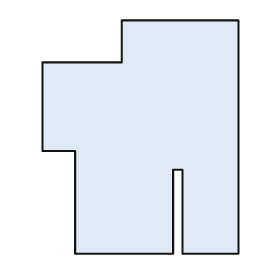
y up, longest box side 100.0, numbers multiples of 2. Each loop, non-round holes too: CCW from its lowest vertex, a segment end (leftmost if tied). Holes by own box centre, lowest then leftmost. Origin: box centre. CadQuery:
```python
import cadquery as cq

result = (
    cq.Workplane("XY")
    .moveTo(-28.0, -50.0)
    .lineTo(14.0, -50.0)
    .lineTo(14.0, -14.0)
    .lineTo(18.0, -14.0)
    .lineTo(18.0, -50.0)
    .lineTo(42.0, -50.0)
    .lineTo(42.0, 50.0)
    .lineTo(-8.0, 50.0)
    .lineTo(-8.0, 32.0)
    .lineTo(-42.0, 32.0)
    .lineTo(-42.0, -6.0)
    .lineTo(-28.0, -6.0)
    .close()
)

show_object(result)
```